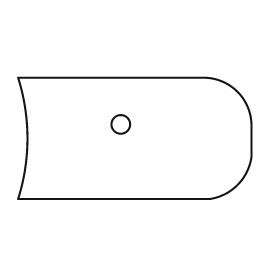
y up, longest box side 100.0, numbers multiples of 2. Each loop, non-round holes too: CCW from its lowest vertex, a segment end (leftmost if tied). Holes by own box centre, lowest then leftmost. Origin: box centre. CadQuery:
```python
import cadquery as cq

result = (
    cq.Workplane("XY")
    .moveTo(-50.0, -26.0)
    .lineTo(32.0, -26.0)
    .threePointArc((44.0, -20.0), (50.0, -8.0))
    .lineTo(50.0, 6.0)
    .threePointArc((44.0, 20.0), (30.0, 26.0))
    .lineTo(-50.0, 26.0)
    .threePointArc((-46.0, 0.0), (-50.0, -26.0))
    .close()
    .moveTo(-6.0, 6.0)
    .circle(4.0)
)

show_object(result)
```